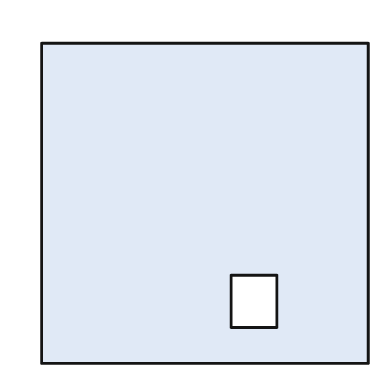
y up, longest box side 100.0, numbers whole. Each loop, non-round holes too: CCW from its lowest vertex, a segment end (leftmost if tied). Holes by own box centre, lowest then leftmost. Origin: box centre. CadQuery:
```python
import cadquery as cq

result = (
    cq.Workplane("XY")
    .moveTo(-50.0, -49.0)
    .lineTo(50.0, -49.0)
    .lineTo(50.0, 49.0)
    .lineTo(-50.0, 49.0)
    .close()
    .moveTo(8.0, -38.0)
    .lineTo(22.0, -38.0)
    .lineTo(22.0, -22.0)
    .lineTo(8.0, -22.0)
    .close()
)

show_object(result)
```